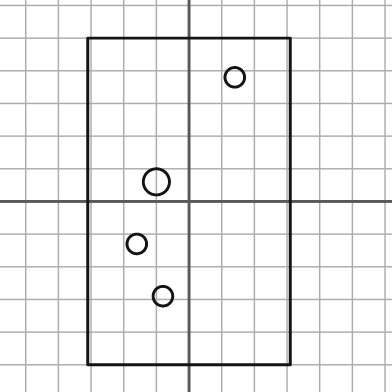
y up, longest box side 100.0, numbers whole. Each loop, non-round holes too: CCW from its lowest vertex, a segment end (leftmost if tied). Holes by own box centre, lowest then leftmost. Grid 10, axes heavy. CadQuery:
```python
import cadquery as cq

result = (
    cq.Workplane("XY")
    .moveTo(-31.0, -50.0)
    .lineTo(31.0, -50.0)
    .lineTo(31.0, 50.0)
    .lineTo(-31.0, 50.0)
    .close()
    .moveTo(-8.0, -29.0)
    .circle(3.0)
    .moveTo(-16.0, -13.0)
    .circle(3.0)
    .moveTo(-10.0, 6.0)
    .circle(4.0)
    .moveTo(14.0, 38.0)
    .circle(3.0)
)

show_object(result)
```